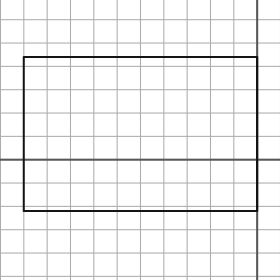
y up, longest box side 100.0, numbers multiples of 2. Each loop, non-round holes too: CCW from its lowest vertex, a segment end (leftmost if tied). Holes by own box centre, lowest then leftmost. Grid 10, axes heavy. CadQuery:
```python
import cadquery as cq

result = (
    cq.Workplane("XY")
    .moveTo(-100.0, -22.0)
    .lineTo(0.0, -22.0)
    .lineTo(0.0, 44.0)
    .lineTo(-100.0, 44.0)
    .close()
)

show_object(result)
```